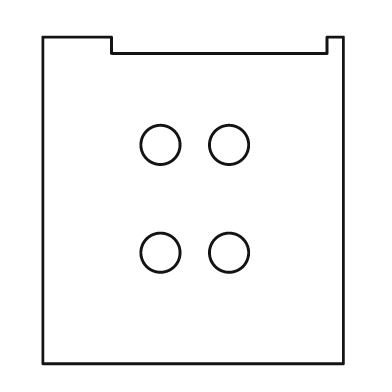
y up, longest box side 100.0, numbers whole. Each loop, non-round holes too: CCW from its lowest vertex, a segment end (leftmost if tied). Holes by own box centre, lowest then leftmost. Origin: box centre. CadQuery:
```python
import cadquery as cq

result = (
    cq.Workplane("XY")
    .moveTo(-46.0, -50.0)
    .lineTo(46.0, -50.0)
    .lineTo(46.0, 50.0)
    .lineTo(41.0, 50.0)
    .lineTo(41.0, 45.0)
    .lineTo(-25.0, 45.0)
    .lineTo(-25.0, 50.0)
    .lineTo(-46.0, 50.0)
    .close()
    .moveTo(-10.0, -16.0)
    .circle(6.0)
    .moveTo(11.0, -16.0)
    .circle(6.0)
    .moveTo(-10.0, 17.0)
    .circle(6.0)
    .moveTo(11.0, 17.0)
    .circle(6.0)
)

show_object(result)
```